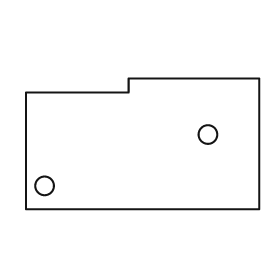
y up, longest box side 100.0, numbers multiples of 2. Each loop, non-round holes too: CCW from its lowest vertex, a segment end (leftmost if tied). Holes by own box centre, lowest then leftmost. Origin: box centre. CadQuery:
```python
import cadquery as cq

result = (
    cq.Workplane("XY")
    .moveTo(-50.0, -28.0)
    .lineTo(50.0, -28.0)
    .lineTo(50.0, 28.0)
    .lineTo(-6.0, 28.0)
    .lineTo(-6.0, 22.0)
    .lineTo(-50.0, 22.0)
    .close()
    .moveTo(-42.0, -18.0)
    .circle(4.0)
    .moveTo(28.0, 4.0)
    .circle(4.0)
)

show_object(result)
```